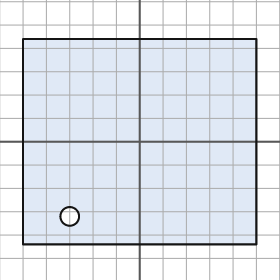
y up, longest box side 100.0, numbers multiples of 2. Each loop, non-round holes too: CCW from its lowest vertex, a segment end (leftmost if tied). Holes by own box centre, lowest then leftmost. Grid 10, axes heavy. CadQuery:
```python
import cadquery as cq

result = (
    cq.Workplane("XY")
    .moveTo(-50.0, -44.0)
    .lineTo(50.0, -44.0)
    .lineTo(50.0, 44.0)
    .lineTo(-50.0, 44.0)
    .close()
    .moveTo(-30.0, -32.0)
    .circle(4.0)
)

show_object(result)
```